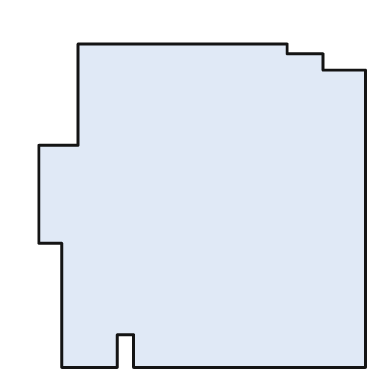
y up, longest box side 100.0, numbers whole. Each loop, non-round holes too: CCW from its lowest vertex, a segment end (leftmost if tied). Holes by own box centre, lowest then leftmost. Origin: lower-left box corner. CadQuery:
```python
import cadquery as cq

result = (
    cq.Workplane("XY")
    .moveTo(7.0, 0.0)
    .lineTo(24.0, 0.0)
    .lineTo(24.0, 10.0)
    .lineTo(29.0, 10.0)
    .lineTo(29.0, 0.0)
    .lineTo(100.0, 0.0)
    .lineTo(100.0, 91.0)
    .lineTo(87.0, 91.0)
    .lineTo(87.0, 96.0)
    .lineTo(76.0, 96.0)
    .lineTo(76.0, 99.0)
    .lineTo(12.0, 99.0)
    .lineTo(12.0, 68.0)
    .lineTo(0.0, 68.0)
    .lineTo(0.0, 38.0)
    .lineTo(7.0, 38.0)
    .close()
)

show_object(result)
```